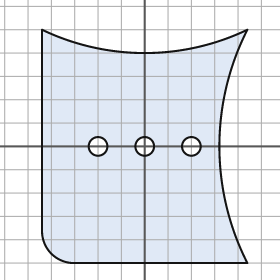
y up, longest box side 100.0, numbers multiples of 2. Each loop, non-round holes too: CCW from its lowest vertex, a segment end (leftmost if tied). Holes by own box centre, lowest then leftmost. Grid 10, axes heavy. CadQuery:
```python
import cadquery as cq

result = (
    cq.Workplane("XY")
    .moveTo(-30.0, -50.0)
    .lineTo(44.0, -50.0)
    .threePointArc((32.0, 0.0), (44.0, 50.0))
    .threePointArc((0.0, 40.0), (-44.0, 50.0))
    .lineTo(-44.0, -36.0)
    .threePointArc((-40.0, -46.0), (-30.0, -50.0))
    .close()
    .moveTo(-20.0, 0.0)
    .circle(4.0)
    .moveTo(0.0, 0.0)
    .circle(4.0)
    .moveTo(20.0, 0.0)
    .circle(4.0)
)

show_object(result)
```